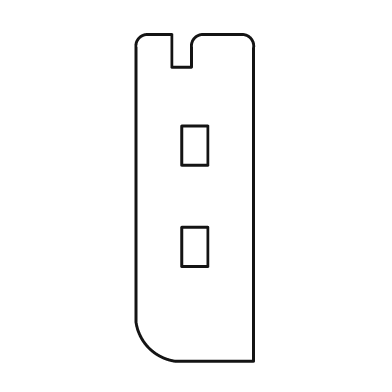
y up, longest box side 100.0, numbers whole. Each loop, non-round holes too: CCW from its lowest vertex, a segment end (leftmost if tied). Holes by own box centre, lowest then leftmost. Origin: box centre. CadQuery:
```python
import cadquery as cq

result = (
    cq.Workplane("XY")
    .moveTo(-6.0, -50.0)
    .lineTo(18.0, -50.0)
    .lineTo(18.0, 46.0)
    .threePointArc((17.0, 49.0), (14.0, 50.0))
    .lineTo(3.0, 50.0)
    .threePointArc((0.0, 49.0), (-1.0, 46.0))
    .lineTo(-1.0, 40.0)
    .lineTo(-7.0, 40.0)
    .lineTo(-7.0, 50.0)
    .lineTo(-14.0, 50.0)
    .threePointArc((-17.0, 49.0), (-18.0, 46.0))
    .lineTo(-18.0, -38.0)
    .threePointArc((-14.0, -46.0), (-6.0, -50.0))
    .close()
    .moveTo(-4.0, -21.0)
    .lineTo(4.0, -21.0)
    .lineTo(4.0, -9.0)
    .lineTo(-4.0, -9.0)
    .close()
    .moveTo(-4.0, 10.0)
    .lineTo(4.0, 10.0)
    .lineTo(4.0, 22.0)
    .lineTo(-4.0, 22.0)
    .close()
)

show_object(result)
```